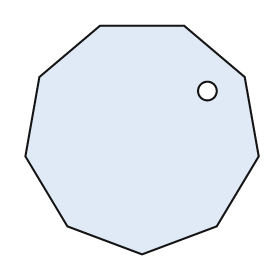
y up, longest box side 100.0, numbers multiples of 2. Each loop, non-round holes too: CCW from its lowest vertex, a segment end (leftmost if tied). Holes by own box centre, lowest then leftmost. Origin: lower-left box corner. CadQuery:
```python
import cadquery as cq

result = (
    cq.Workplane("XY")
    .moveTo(50.0, 0.0)
    .lineTo(82.0, 12.0)
    .lineTo(100.0, 42.0)
    .lineTo(94.0, 76.0)
    .lineTo(68.0, 98.0)
    .lineTo(32.0, 98.0)
    .lineTo(6.0, 76.0)
    .lineTo(0.0, 42.0)
    .lineTo(18.0, 12.0)
    .close()
    .moveTo(78.0, 70.0)
    .circle(4.0)
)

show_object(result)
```